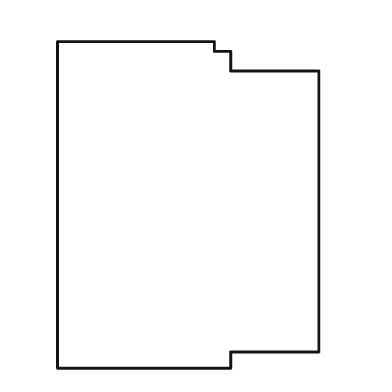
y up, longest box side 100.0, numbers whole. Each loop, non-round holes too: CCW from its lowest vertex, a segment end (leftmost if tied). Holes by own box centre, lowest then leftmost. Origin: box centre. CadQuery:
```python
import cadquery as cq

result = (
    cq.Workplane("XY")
    .moveTo(-40.0, -50.0)
    .lineTo(13.0, -50.0)
    .lineTo(13.0, -45.0)
    .lineTo(40.0, -45.0)
    .lineTo(40.0, 41.0)
    .lineTo(13.0, 41.0)
    .lineTo(13.0, 47.0)
    .lineTo(8.0, 47.0)
    .lineTo(8.0, 50.0)
    .lineTo(-40.0, 50.0)
    .close()
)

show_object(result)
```